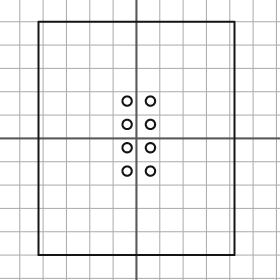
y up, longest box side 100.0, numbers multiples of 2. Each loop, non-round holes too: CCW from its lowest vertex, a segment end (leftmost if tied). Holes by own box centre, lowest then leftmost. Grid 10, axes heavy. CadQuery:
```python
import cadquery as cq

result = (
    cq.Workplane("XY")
    .moveTo(-42.0, -50.0)
    .lineTo(42.0, -50.0)
    .lineTo(42.0, 50.0)
    .lineTo(-42.0, 50.0)
    .close()
    .moveTo(-4.0, -14.0)
    .circle(2.0)
    .moveTo(6.0, -14.0)
    .circle(2.0)
    .moveTo(-4.0, -4.0)
    .circle(2.0)
    .moveTo(6.0, -4.0)
    .circle(2.0)
    .moveTo(-4.0, 6.0)
    .circle(2.0)
    .moveTo(6.0, 6.0)
    .circle(2.0)
    .moveTo(-4.0, 16.0)
    .circle(2.0)
    .moveTo(6.0, 16.0)
    .circle(2.0)
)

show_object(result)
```